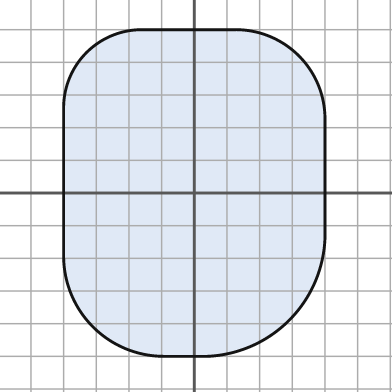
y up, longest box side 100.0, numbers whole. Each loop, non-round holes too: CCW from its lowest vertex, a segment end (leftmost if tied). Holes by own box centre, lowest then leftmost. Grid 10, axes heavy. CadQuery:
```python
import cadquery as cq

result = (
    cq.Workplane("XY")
    .moveTo(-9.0, -50.0)
    .lineTo(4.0, -50.0)
    .threePointArc((29.0, -39.0), (40.0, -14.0))
    .lineTo(40.0, 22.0)
    .threePointArc((32.0, 42.0), (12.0, 50.0))
    .lineTo(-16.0, 50.0)
    .threePointArc((-33.0, 43.0), (-40.0, 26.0))
    .lineTo(-40.0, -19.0)
    .threePointArc((-31.0, -41.0), (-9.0, -50.0))
    .close()
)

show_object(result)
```